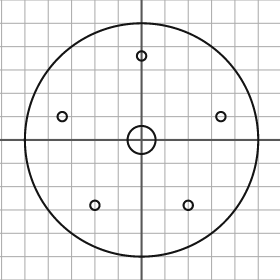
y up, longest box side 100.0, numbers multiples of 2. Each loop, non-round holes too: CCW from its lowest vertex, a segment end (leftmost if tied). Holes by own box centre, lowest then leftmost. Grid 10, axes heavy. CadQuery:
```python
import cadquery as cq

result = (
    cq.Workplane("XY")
    .moveTo(0.0, 0.0)
    .circle(50.0)
    .moveTo(-20.0, -28.0)
    .circle(2.0)
    .moveTo(20.0, -28.0)
    .circle(2.0)
    .moveTo(0.0, 0.0)
    .circle(6.0)
    .moveTo(-34.0, 10.0)
    .circle(2.0)
    .moveTo(34.0, 10.0)
    .circle(2.0)
    .moveTo(0.0, 36.0)
    .circle(2.0)
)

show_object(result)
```